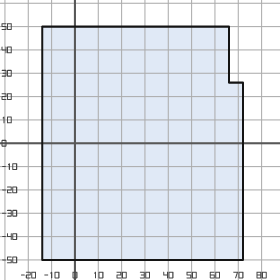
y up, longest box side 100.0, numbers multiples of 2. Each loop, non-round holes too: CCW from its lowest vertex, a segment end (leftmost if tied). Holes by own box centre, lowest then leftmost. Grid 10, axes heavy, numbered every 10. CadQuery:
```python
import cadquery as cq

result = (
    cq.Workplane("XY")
    .moveTo(-14.0, -50.0)
    .lineTo(72.0, -50.0)
    .lineTo(72.0, 26.0)
    .lineTo(66.0, 26.0)
    .lineTo(66.0, 50.0)
    .lineTo(-14.0, 50.0)
    .close()
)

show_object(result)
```